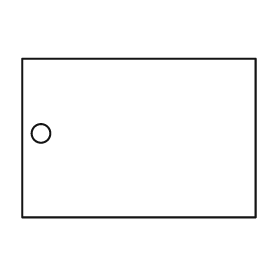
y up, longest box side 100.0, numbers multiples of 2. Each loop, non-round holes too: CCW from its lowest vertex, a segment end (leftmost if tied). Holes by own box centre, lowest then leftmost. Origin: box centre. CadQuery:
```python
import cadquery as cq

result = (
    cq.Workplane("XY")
    .moveTo(-50.0, -34.0)
    .lineTo(50.0, -34.0)
    .lineTo(50.0, 34.0)
    .lineTo(-50.0, 34.0)
    .close()
    .moveTo(-42.0, 2.0)
    .circle(4.0)
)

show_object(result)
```